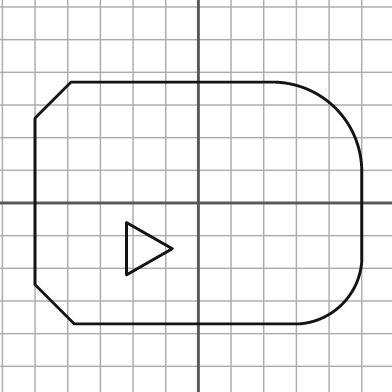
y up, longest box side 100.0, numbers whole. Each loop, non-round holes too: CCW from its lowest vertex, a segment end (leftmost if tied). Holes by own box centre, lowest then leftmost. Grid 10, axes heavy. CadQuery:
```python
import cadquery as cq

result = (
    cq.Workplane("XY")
    .moveTo(-38.0, -37.0)
    .lineTo(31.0, -37.0)
    .threePointArc((44.0, -31.0), (50.0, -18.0))
    .lineTo(50.0, 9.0)
    .threePointArc((42.0, 29.0), (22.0, 37.0))
    .lineTo(-39.0, 37.0)
    .lineTo(-50.0, 26.0)
    .lineTo(-50.0, -25.0)
    .close()
    .moveTo(-22.0, -22.0)
    .lineTo(-8.0, -14.0)
    .lineTo(-22.0, -6.0)
    .close()
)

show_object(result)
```